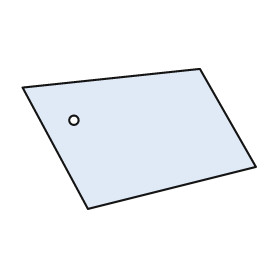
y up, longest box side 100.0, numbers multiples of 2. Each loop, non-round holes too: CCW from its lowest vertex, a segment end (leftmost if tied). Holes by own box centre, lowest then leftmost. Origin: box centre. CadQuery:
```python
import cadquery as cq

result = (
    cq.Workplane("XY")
    .moveTo(-22.0, -30.0)
    .lineTo(50.0, -12.0)
    .lineTo(26.0, 30.0)
    .lineTo(-50.0, 22.0)
    .close()
    .moveTo(-28.0, 8.0)
    .circle(2.0)
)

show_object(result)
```